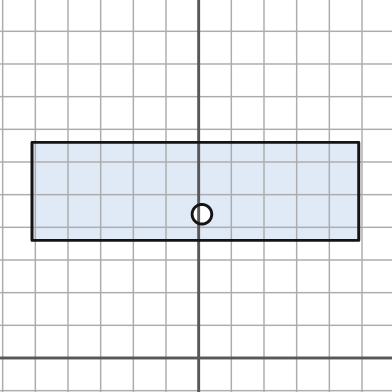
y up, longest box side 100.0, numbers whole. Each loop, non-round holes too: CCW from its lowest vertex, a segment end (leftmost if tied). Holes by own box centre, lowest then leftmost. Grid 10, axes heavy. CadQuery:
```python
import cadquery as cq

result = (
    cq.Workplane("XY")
    .moveTo(-51.0, 36.0)
    .lineTo(49.0, 36.0)
    .lineTo(49.0, 66.0)
    .lineTo(-51.0, 66.0)
    .close()
    .moveTo(1.0, 44.0)
    .circle(3.0)
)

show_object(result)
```